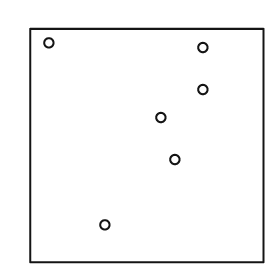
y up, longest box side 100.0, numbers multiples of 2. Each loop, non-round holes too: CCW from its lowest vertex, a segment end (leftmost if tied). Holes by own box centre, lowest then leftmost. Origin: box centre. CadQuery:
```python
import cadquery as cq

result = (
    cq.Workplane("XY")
    .moveTo(-50.0, -50.0)
    .lineTo(50.0, -50.0)
    .lineTo(50.0, 50.0)
    .lineTo(-50.0, 50.0)
    .close()
    .moveTo(-18.0, -34.0)
    .circle(2.0)
    .moveTo(12.0, -6.0)
    .circle(2.0)
    .moveTo(6.0, 12.0)
    .circle(2.0)
    .moveTo(24.0, 24.0)
    .circle(2.0)
    .moveTo(24.0, 42.0)
    .circle(2.0)
    .moveTo(-42.0, 44.0)
    .circle(2.0)
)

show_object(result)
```